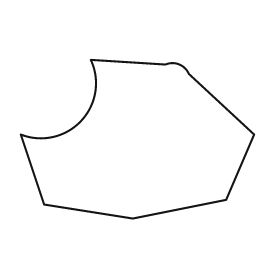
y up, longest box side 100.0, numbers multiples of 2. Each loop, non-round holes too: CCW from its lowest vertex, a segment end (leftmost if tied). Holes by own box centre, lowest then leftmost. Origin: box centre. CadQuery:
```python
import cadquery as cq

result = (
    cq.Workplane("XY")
    .moveTo(-2.0, -34.0)
    .lineTo(38.0, -26.0)
    .lineTo(50.0, 2.0)
    .lineTo(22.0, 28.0)
    .threePointArc((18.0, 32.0), (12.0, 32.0))
    .lineTo(-20.0, 34.0)
    .threePointArc((-24.0, 8.0), (-50.0, 2.0))
    .lineTo(-40.0, -28.0)
    .close()
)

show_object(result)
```